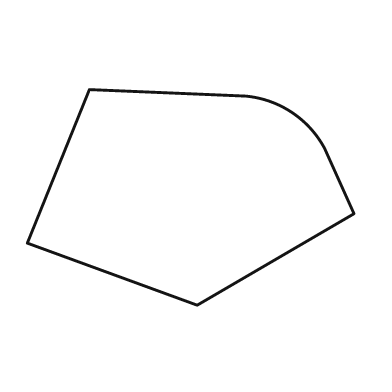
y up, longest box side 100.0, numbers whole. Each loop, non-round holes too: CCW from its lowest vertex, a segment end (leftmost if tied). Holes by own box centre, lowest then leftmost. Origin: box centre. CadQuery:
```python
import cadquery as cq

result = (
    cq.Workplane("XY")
    .moveTo(2.0, -33.0)
    .lineTo(50.0, -5.0)
    .lineTo(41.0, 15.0)
    .threePointArc((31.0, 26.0), (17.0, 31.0))
    .lineTo(-31.0, 33.0)
    .lineTo(-50.0, -14.0)
    .close()
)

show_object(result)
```